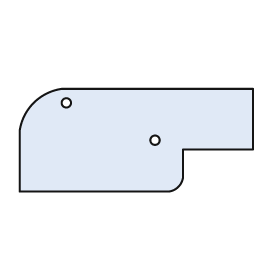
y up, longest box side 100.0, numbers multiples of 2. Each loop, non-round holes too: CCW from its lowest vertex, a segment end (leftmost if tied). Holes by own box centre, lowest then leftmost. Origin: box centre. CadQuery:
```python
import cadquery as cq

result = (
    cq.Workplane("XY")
    .moveTo(-50.0, -22.0)
    .lineTo(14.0, -22.0)
    .threePointArc((18.0, -20.0), (20.0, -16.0))
    .lineTo(20.0, -4.0)
    .lineTo(50.0, -4.0)
    .lineTo(50.0, 22.0)
    .lineTo(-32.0, 22.0)
    .threePointArc((-44.0, 16.0), (-50.0, 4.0))
    .close()
    .moveTo(8.0, 0.0)
    .circle(2.0)
    .moveTo(-30.0, 16.0)
    .circle(2.0)
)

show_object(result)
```